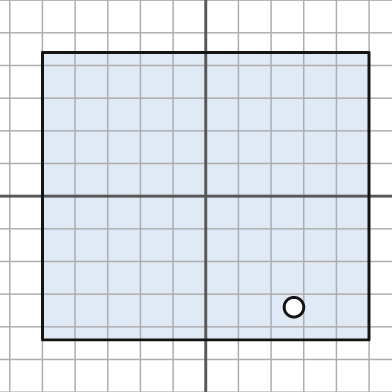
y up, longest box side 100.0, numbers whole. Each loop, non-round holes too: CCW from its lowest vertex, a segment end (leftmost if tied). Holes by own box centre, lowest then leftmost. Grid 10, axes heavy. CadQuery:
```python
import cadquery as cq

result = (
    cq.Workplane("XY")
    .moveTo(-50.0, -44.0)
    .lineTo(50.0, -44.0)
    .lineTo(50.0, 44.0)
    .lineTo(-50.0, 44.0)
    .close()
    .moveTo(27.0, -34.0)
    .circle(3.0)
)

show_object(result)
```